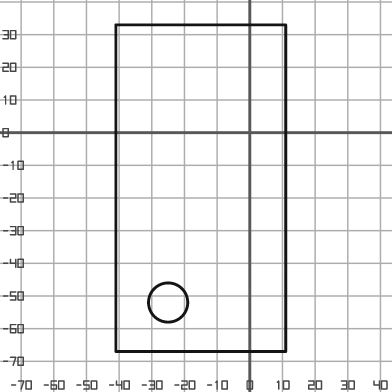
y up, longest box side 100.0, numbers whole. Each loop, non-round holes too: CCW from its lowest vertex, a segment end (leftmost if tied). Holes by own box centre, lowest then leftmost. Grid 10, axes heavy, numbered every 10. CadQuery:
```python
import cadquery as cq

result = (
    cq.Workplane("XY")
    .moveTo(-41.0, -67.0)
    .lineTo(11.0, -67.0)
    .lineTo(11.0, 33.0)
    .lineTo(-41.0, 33.0)
    .close()
    .moveTo(-25.0, -52.0)
    .circle(6.0)
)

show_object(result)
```